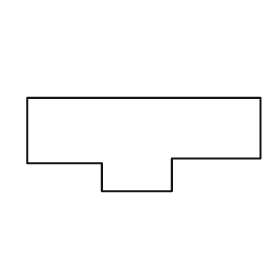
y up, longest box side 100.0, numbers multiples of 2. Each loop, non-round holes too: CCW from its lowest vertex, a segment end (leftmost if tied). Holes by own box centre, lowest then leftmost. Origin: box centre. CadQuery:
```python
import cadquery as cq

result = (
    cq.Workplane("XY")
    .moveTo(-18.0, -20.0)
    .lineTo(12.0, -20.0)
    .lineTo(12.0, -6.0)
    .lineTo(50.0, -6.0)
    .lineTo(50.0, 20.0)
    .lineTo(-50.0, 20.0)
    .lineTo(-50.0, -8.0)
    .lineTo(-18.0, -8.0)
    .close()
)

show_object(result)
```